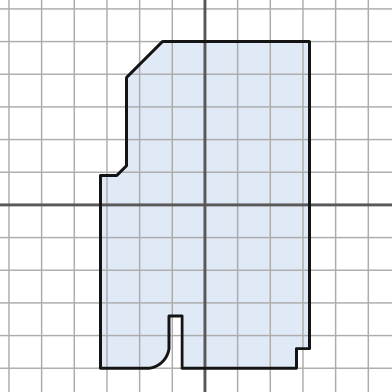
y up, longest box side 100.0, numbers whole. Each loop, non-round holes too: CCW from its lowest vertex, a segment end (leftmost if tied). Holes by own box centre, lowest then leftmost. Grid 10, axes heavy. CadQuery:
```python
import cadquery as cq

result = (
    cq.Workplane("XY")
    .moveTo(-32.0, -50.0)
    .lineTo(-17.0, -50.0)
    .threePointArc((-13.0, -48.0), (-11.0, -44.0))
    .lineTo(-11.0, -34.0)
    .lineTo(-7.0, -34.0)
    .lineTo(-7.0, -50.0)
    .lineTo(28.0, -50.0)
    .lineTo(28.0, -44.0)
    .lineTo(32.0, -44.0)
    .lineTo(32.0, 50.0)
    .lineTo(-13.0, 50.0)
    .lineTo(-24.0, 39.0)
    .lineTo(-24.0, 12.0)
    .lineTo(-27.0, 9.0)
    .lineTo(-32.0, 9.0)
    .close()
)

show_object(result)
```